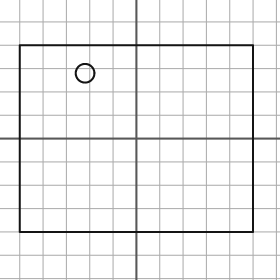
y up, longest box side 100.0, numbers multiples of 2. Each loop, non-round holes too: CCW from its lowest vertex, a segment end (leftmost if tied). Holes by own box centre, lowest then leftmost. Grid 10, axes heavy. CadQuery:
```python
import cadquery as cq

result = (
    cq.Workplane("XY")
    .moveTo(-50.0, -40.0)
    .lineTo(50.0, -40.0)
    .lineTo(50.0, 40.0)
    .lineTo(-50.0, 40.0)
    .close()
    .moveTo(-22.0, 28.0)
    .circle(4.0)
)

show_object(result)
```